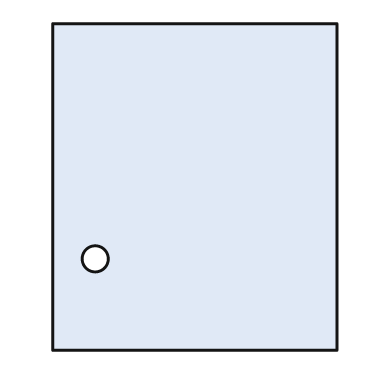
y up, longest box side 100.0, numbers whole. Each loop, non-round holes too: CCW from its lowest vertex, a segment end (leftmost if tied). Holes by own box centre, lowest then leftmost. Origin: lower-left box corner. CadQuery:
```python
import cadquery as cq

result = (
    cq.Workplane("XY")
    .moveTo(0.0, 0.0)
    .lineTo(87.0, 0.0)
    .lineTo(87.0, 100.0)
    .lineTo(0.0, 100.0)
    .close()
    .moveTo(13.0, 28.0)
    .circle(4.0)
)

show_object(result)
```